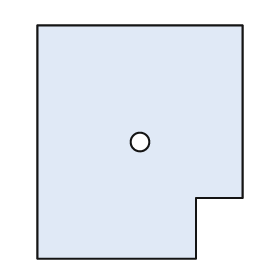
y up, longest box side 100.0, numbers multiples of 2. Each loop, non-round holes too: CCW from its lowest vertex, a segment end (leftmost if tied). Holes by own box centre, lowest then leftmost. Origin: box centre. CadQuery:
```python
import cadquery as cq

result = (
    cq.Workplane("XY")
    .moveTo(-44.0, -50.0)
    .lineTo(24.0, -50.0)
    .lineTo(24.0, -24.0)
    .lineTo(44.0, -24.0)
    .lineTo(44.0, 50.0)
    .lineTo(-44.0, 50.0)
    .close()
    .moveTo(0.0, 0.0)
    .circle(4.0)
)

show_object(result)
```